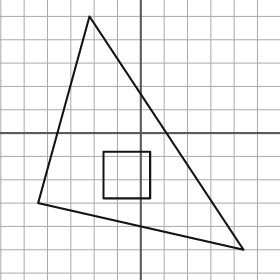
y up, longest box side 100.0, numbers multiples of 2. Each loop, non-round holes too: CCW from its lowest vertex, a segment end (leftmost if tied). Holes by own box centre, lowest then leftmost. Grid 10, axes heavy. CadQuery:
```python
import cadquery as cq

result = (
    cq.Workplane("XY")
    .moveTo(44.0, -50.0)
    .lineTo(-22.0, 50.0)
    .lineTo(-44.0, -30.0)
    .close()
    .moveTo(-16.0, -28.0)
    .lineTo(4.0, -28.0)
    .lineTo(4.0, -8.0)
    .lineTo(-16.0, -8.0)
    .close()
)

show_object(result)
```